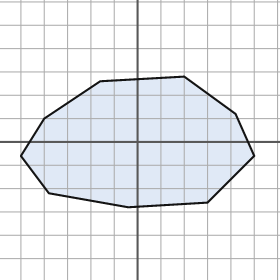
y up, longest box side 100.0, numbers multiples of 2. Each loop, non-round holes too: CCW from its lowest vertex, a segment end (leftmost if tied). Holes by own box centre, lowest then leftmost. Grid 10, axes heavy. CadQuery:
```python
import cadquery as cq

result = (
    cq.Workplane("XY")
    .moveTo(-4.0, -28.0)
    .lineTo(30.0, -26.0)
    .lineTo(50.0, -6.0)
    .lineTo(42.0, 12.0)
    .lineTo(20.0, 28.0)
    .lineTo(-16.0, 26.0)
    .lineTo(-40.0, 10.0)
    .lineTo(-50.0, -6.0)
    .lineTo(-38.0, -22.0)
    .close()
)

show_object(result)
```